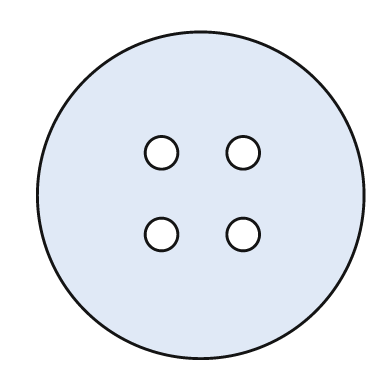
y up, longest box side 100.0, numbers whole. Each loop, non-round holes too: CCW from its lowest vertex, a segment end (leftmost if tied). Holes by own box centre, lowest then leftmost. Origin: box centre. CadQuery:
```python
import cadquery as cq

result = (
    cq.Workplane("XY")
    .moveTo(0.0, 0.0)
    .circle(50.0)
    .moveTo(-12.0, -12.0)
    .circle(5.0)
    .moveTo(13.0, -12.0)
    .circle(5.0)
    .moveTo(-12.0, 13.0)
    .circle(5.0)
    .moveTo(13.0, 13.0)
    .circle(5.0)
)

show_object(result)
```